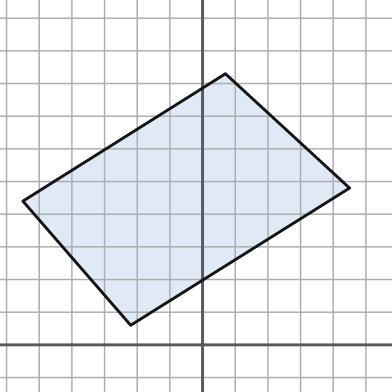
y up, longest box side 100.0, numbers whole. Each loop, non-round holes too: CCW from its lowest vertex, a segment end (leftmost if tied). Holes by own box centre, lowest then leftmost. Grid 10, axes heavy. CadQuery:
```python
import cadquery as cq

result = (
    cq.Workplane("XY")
    .moveTo(-22.0, 6.0)
    .lineTo(45.0, 48.0)
    .lineTo(7.0, 83.0)
    .lineTo(-55.0, 44.0)
    .close()
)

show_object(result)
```